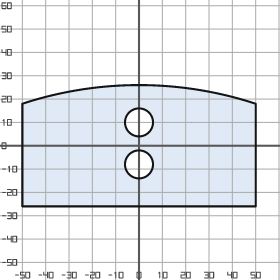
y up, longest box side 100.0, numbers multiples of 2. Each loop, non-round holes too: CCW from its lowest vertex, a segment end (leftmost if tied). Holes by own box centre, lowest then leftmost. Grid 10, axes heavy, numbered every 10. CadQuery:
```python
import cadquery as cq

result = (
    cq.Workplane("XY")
    .moveTo(-50.0, -26.0)
    .lineTo(50.0, -26.0)
    .lineTo(50.0, 18.0)
    .threePointArc((0.0, 26.0), (-50.0, 18.0))
    .close()
    .moveTo(0.0, -8.0)
    .circle(6.0)
    .moveTo(0.0, 10.0)
    .circle(6.0)
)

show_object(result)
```